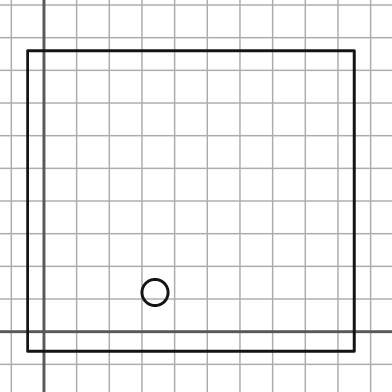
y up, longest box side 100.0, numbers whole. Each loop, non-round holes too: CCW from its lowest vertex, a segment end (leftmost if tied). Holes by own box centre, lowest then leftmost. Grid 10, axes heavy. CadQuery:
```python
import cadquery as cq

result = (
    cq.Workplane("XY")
    .moveTo(-5.0, -6.0)
    .lineTo(95.0, -6.0)
    .lineTo(95.0, 86.0)
    .lineTo(-5.0, 86.0)
    .close()
    .moveTo(34.0, 12.0)
    .circle(4.0)
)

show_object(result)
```